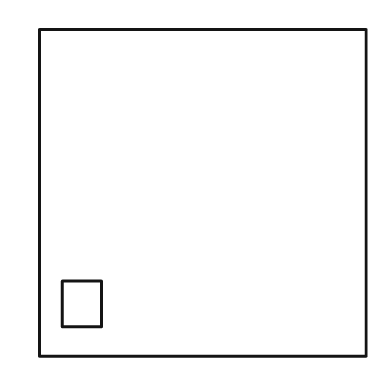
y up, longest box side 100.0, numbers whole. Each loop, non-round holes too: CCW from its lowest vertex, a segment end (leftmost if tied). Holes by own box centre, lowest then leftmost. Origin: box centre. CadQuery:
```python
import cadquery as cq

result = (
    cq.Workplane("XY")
    .moveTo(-50.0, -50.0)
    .lineTo(50.0, -50.0)
    .lineTo(50.0, 50.0)
    .lineTo(-50.0, 50.0)
    .close()
    .moveTo(-43.0, -41.0)
    .lineTo(-31.0, -41.0)
    .lineTo(-31.0, -27.0)
    .lineTo(-43.0, -27.0)
    .close()
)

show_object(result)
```